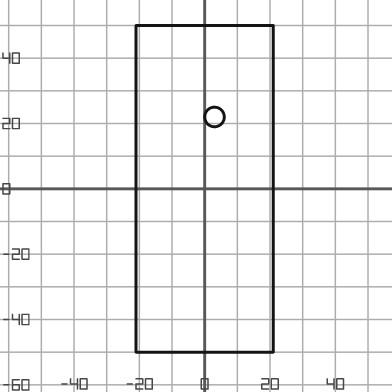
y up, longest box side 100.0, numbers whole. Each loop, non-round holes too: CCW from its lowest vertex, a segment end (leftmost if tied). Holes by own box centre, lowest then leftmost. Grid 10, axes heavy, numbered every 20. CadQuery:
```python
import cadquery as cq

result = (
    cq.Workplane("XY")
    .moveTo(-21.0, -50.0)
    .lineTo(21.0, -50.0)
    .lineTo(21.0, 50.0)
    .lineTo(-21.0, 50.0)
    .close()
    .moveTo(3.0, 22.0)
    .circle(3.0)
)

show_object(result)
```